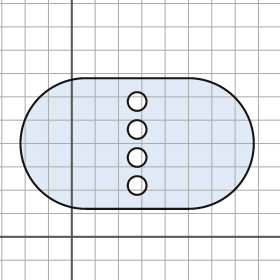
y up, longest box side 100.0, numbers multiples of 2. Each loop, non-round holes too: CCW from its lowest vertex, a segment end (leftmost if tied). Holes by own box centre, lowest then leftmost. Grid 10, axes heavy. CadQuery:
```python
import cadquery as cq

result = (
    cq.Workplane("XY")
    .moveTo(6.0, 12.0)
    .lineTo(50.0, 12.0)
    .threePointArc((78.0, 40.0), (50.0, 68.0))
    .lineTo(6.0, 68.0)
    .threePointArc((-22.0, 40.0), (6.0, 12.0))
    .close()
    .moveTo(28.0, 22.0)
    .circle(4.0)
    .moveTo(28.0, 34.0)
    .circle(4.0)
    .moveTo(28.0, 46.0)
    .circle(4.0)
    .moveTo(28.0, 58.0)
    .circle(4.0)
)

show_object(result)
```